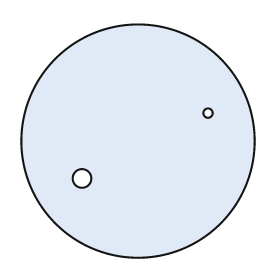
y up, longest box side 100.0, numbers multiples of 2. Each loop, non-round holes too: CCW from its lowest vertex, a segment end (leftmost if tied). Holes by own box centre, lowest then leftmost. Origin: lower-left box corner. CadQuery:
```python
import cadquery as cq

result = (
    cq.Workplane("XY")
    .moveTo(50.0, 50.0)
    .circle(50.0)
    .moveTo(26.0, 34.0)
    .circle(4.0)
    .moveTo(80.0, 62.0)
    .circle(2.0)
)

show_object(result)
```